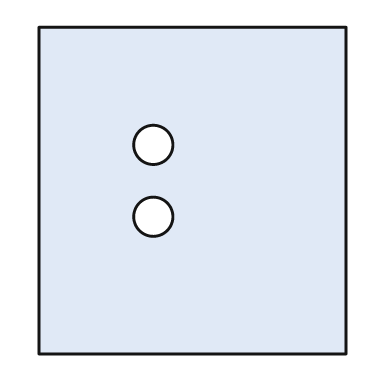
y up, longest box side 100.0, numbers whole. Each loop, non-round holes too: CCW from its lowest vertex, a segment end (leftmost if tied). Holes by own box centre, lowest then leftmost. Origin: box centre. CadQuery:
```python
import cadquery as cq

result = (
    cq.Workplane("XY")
    .moveTo(-47.0, -50.0)
    .lineTo(47.0, -50.0)
    .lineTo(47.0, 50.0)
    .lineTo(-47.0, 50.0)
    .close()
    .moveTo(-12.0, -8.0)
    .circle(6.0)
    .moveTo(-12.0, 14.0)
    .circle(6.0)
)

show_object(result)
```